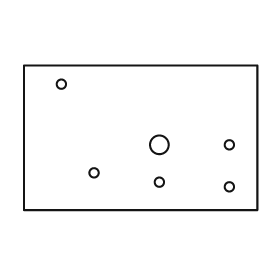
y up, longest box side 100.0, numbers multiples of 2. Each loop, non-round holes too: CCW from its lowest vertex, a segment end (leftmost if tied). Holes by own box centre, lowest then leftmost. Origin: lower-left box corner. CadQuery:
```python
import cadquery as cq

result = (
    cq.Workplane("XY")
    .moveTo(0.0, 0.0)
    .lineTo(100.0, 0.0)
    .lineTo(100.0, 62.0)
    .lineTo(0.0, 62.0)
    .close()
    .moveTo(88.0, 10.0)
    .circle(2.0)
    .moveTo(58.0, 12.0)
    .circle(2.0)
    .moveTo(30.0, 16.0)
    .circle(2.0)
    .moveTo(58.0, 28.0)
    .circle(4.0)
    .moveTo(88.0, 28.0)
    .circle(2.0)
    .moveTo(16.0, 54.0)
    .circle(2.0)
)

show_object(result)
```